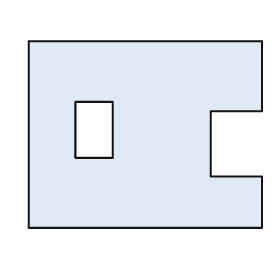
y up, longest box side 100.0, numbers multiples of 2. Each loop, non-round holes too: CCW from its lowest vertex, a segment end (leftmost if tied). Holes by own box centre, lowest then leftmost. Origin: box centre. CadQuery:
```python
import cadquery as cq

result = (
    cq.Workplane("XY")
    .moveTo(-50.0, -40.0)
    .lineTo(50.0, -40.0)
    .lineTo(50.0, -18.0)
    .lineTo(28.0, -18.0)
    .lineTo(28.0, 10.0)
    .lineTo(50.0, 10.0)
    .lineTo(50.0, 40.0)
    .lineTo(-50.0, 40.0)
    .close()
    .moveTo(-30.0, -10.0)
    .lineTo(-14.0, -10.0)
    .lineTo(-14.0, 14.0)
    .lineTo(-30.0, 14.0)
    .close()
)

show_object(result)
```